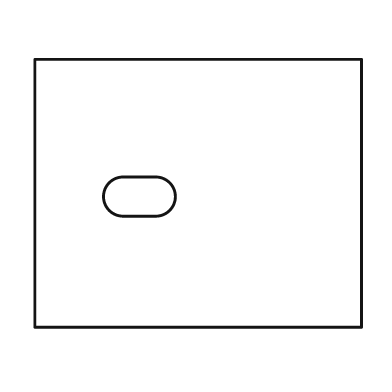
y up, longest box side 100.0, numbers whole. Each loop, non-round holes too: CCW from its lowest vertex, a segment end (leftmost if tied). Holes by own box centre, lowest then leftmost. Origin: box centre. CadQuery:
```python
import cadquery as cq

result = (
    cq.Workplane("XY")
    .moveTo(-50.0, -41.0)
    .lineTo(50.0, -41.0)
    .lineTo(50.0, 41.0)
    .lineTo(-50.0, 41.0)
    .close()
    .moveTo(-23.0, -7.0)
    .lineTo(-13.0, -7.0)
    .threePointArc((-7.0, -1.0), (-13.0, 5.0))
    .lineTo(-23.0, 5.0)
    .threePointArc((-29.0, -1.0), (-23.0, -7.0))
    .close()
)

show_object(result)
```